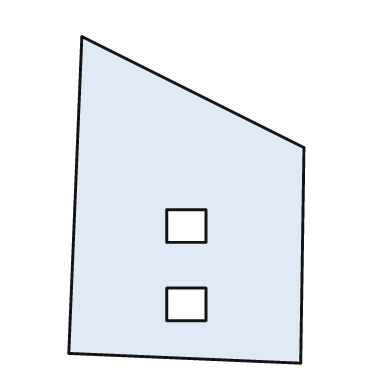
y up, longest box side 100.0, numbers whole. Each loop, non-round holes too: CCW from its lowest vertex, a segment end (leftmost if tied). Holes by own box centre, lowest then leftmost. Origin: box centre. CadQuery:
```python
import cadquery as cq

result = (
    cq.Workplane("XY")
    .moveTo(35.0, -50.0)
    .lineTo(36.0, 16.0)
    .lineTo(-32.0, 50.0)
    .lineTo(-36.0, -47.0)
    .close()
    .moveTo(-6.0, -37.0)
    .lineTo(6.0, -37.0)
    .lineTo(6.0, -27.0)
    .lineTo(-6.0, -27.0)
    .close()
    .moveTo(-6.0, -13.0)
    .lineTo(6.0, -13.0)
    .lineTo(6.0, -3.0)
    .lineTo(-6.0, -3.0)
    .close()
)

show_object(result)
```